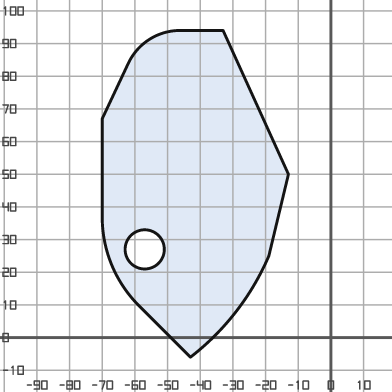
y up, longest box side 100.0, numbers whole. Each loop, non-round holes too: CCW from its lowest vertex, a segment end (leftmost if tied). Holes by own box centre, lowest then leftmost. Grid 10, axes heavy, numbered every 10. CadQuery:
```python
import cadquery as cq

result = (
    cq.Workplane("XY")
    .moveTo(-43.0, -6.0)
    .threePointArc((-29.0, 8.0), (-19.0, 25.0))
    .lineTo(-13.0, 50.0)
    .lineTo(-33.0, 94.0)
    .lineTo(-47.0, 94.0)
    .threePointArc((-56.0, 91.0), (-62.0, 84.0))
    .lineTo(-70.0, 67.0)
    .lineTo(-70.0, 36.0)
    .threePointArc((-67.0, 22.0), (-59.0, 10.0))
    .close()
    .moveTo(-57.0, 27.0)
    .circle(6.0)
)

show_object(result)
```